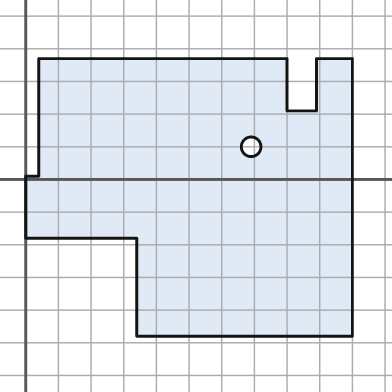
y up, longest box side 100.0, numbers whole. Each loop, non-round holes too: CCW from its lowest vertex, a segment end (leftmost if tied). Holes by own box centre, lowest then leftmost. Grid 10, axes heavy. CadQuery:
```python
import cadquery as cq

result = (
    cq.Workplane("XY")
    .moveTo(34.0, -48.0)
    .lineTo(100.0, -48.0)
    .lineTo(100.0, 37.0)
    .lineTo(89.0, 37.0)
    .lineTo(89.0, 21.0)
    .lineTo(80.0, 21.0)
    .lineTo(80.0, 37.0)
    .lineTo(4.0, 37.0)
    .lineTo(4.0, 1.0)
    .lineTo(0.0, 1.0)
    .lineTo(0.0, -18.0)
    .lineTo(34.0, -18.0)
    .close()
    .moveTo(69.0, 10.0)
    .circle(3.0)
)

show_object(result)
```